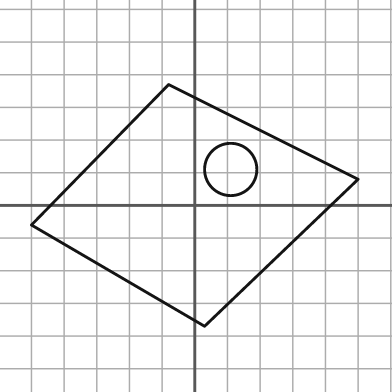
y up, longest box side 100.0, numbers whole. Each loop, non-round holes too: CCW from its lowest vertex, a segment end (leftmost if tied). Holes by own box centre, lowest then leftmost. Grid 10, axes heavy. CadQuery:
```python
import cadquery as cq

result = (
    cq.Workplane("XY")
    .moveTo(3.0, -37.0)
    .lineTo(50.0, 8.0)
    .lineTo(-8.0, 37.0)
    .lineTo(-50.0, -6.0)
    .close()
    .moveTo(11.0, 11.0)
    .circle(8.0)
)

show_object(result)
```